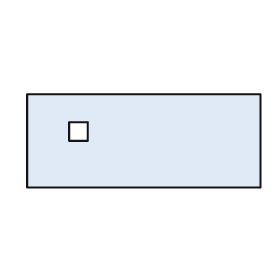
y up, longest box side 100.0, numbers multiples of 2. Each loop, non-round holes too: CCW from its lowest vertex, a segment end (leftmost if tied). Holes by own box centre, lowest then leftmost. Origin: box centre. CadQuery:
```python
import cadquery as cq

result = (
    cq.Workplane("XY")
    .moveTo(-50.0, -20.0)
    .lineTo(50.0, -20.0)
    .lineTo(50.0, 20.0)
    .lineTo(-50.0, 20.0)
    .close()
    .moveTo(-32.0, 0.0)
    .lineTo(-24.0, 0.0)
    .lineTo(-24.0, 8.0)
    .lineTo(-32.0, 8.0)
    .close()
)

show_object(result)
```